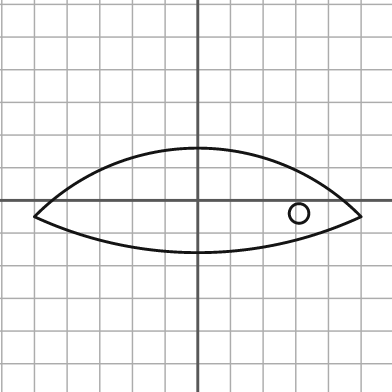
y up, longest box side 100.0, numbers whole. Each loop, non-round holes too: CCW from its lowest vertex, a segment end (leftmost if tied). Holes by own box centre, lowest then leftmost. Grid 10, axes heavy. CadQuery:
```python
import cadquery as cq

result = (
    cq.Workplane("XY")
    .moveTo(-50.0, -5.0)
    .threePointArc((0.0, -16.0), (50.0, -5.0))
    .threePointArc((0.0, 16.0), (-50.0, -5.0))
    .close()
    .moveTo(31.0, -4.0)
    .circle(3.0)
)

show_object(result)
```